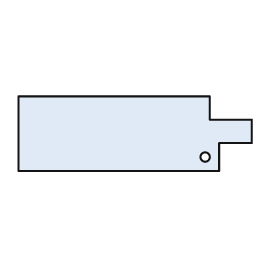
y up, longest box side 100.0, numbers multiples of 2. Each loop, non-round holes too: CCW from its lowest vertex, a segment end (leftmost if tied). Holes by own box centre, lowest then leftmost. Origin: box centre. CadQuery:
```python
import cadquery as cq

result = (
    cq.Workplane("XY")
    .moveTo(-50.0, -16.0)
    .lineTo(36.0, -16.0)
    .lineTo(36.0, -4.0)
    .lineTo(50.0, -4.0)
    .lineTo(50.0, 6.0)
    .lineTo(32.0, 6.0)
    .lineTo(32.0, 16.0)
    .lineTo(-50.0, 16.0)
    .close()
    .moveTo(30.0, -10.0)
    .circle(2.0)
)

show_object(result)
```